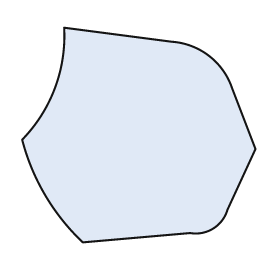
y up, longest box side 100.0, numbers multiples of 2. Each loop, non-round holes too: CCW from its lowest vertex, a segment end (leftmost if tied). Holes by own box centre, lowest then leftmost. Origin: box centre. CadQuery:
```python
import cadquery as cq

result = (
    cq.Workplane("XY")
    .moveTo(-24.0, -46.0)
    .lineTo(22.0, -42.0)
    .threePointArc((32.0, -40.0), (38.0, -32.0))
    .lineTo(50.0, -6.0)
    .lineTo(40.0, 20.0)
    .threePointArc((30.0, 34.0), (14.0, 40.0))
    .lineTo(-32.0, 46.0)
    .threePointArc((-36.0, 20.0), (-50.0, -2.0))
    .threePointArc((-40.0, -26.0), (-24.0, -46.0))
    .close()
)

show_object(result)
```